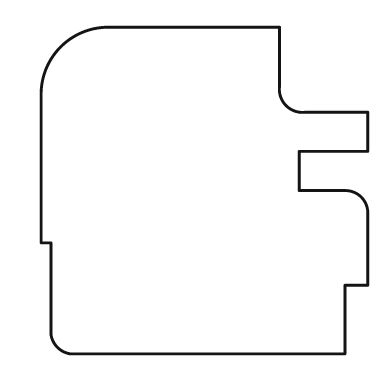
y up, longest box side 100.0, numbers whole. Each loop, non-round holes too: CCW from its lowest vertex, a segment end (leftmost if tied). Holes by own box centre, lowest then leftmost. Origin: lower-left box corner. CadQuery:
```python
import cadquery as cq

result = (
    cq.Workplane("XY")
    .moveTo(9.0, 0.0)
    .lineTo(93.0, 0.0)
    .lineTo(93.0, 21.0)
    .lineTo(100.0, 21.0)
    .lineTo(100.0, 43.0)
    .threePointArc((98.0, 48.0), (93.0, 50.0))
    .lineTo(79.0, 50.0)
    .lineTo(79.0, 62.0)
    .lineTo(100.0, 62.0)
    .lineTo(100.0, 74.0)
    .lineTo(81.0, 74.0)
    .threePointArc((75.0, 76.0), (73.0, 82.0))
    .lineTo(73.0, 100.0)
    .lineTo(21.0, 100.0)
    .threePointArc((6.0, 94.0), (0.0, 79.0))
    .lineTo(0.0, 34.0)
    .lineTo(3.0, 34.0)
    .lineTo(3.0, 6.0)
    .threePointArc((5.0, 2.0), (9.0, 0.0))
    .close()
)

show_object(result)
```